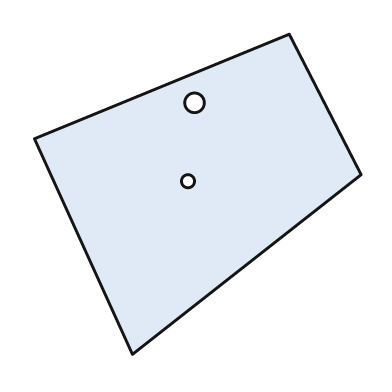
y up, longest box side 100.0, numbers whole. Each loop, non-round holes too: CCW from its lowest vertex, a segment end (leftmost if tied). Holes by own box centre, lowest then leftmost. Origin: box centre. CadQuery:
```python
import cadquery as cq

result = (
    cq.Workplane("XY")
    .moveTo(-20.0, -49.0)
    .lineTo(50.0, 6.0)
    .lineTo(28.0, 49.0)
    .lineTo(-50.0, 17.0)
    .close()
    .moveTo(-3.0, 4.0)
    .circle(2.0)
    .moveTo(-1.0, 28.0)
    .circle(3.0)
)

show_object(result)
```